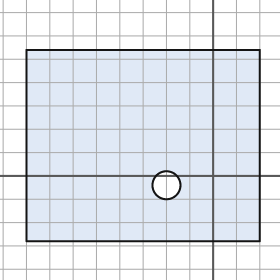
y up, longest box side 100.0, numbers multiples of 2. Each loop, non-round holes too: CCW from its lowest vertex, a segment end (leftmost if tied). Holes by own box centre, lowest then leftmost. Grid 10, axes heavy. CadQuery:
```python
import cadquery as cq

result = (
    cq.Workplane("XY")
    .moveTo(-80.0, -28.0)
    .lineTo(20.0, -28.0)
    .lineTo(20.0, 54.0)
    .lineTo(-80.0, 54.0)
    .close()
    .moveTo(-20.0, -4.0)
    .circle(6.0)
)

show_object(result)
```